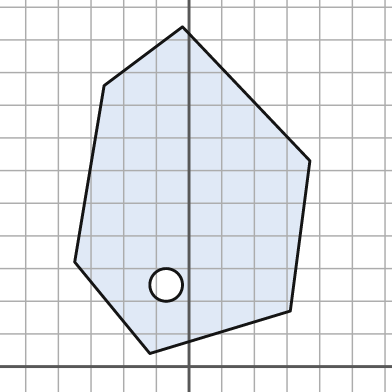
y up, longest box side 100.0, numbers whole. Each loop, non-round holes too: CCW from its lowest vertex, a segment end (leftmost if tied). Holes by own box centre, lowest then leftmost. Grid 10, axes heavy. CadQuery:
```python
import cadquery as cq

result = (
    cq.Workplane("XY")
    .moveTo(-12.0, 4.0)
    .lineTo(31.0, 17.0)
    .lineTo(37.0, 63.0)
    .lineTo(-2.0, 104.0)
    .lineTo(-26.0, 86.0)
    .lineTo(-35.0, 32.0)
    .close()
    .moveTo(-7.0, 25.0)
    .circle(5.0)
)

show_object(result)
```